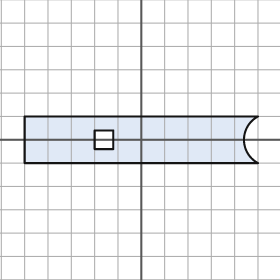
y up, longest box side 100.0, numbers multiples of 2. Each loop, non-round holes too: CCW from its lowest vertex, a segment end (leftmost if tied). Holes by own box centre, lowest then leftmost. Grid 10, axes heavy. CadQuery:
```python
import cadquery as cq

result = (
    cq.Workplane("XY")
    .moveTo(-50.0, -10.0)
    .lineTo(50.0, -10.0)
    .threePointArc((44.0, 0.0), (50.0, 10.0))
    .lineTo(-50.0, 10.0)
    .close()
    .moveTo(-20.0, -4.0)
    .lineTo(-12.0, -4.0)
    .lineTo(-12.0, 4.0)
    .lineTo(-20.0, 4.0)
    .close()
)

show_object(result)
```